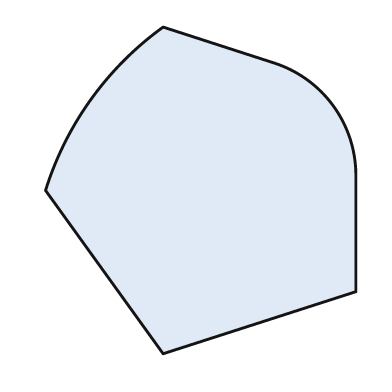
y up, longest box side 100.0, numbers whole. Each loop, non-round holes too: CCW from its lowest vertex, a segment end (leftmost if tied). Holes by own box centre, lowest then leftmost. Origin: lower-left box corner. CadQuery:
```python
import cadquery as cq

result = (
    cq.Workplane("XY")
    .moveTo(36.0, 0.0)
    .lineTo(95.0, 19.0)
    .lineTo(95.0, 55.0)
    .threePointArc((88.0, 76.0), (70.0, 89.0))
    .lineTo(36.0, 100.0)
    .threePointArc((14.0, 78.0), (0.0, 50.0))
    .close()
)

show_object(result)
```